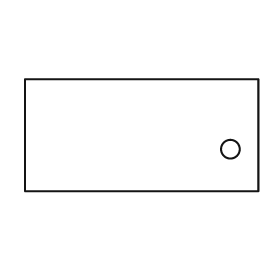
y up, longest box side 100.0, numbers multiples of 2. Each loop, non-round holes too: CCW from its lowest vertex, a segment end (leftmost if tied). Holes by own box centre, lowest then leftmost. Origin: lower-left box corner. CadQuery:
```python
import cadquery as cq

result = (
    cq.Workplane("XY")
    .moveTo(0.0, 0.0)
    .lineTo(100.0, 0.0)
    .lineTo(100.0, 48.0)
    .lineTo(0.0, 48.0)
    .close()
    .moveTo(88.0, 18.0)
    .circle(4.0)
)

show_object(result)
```